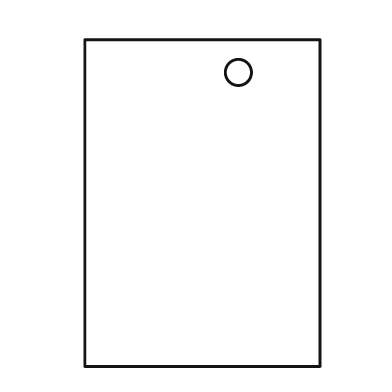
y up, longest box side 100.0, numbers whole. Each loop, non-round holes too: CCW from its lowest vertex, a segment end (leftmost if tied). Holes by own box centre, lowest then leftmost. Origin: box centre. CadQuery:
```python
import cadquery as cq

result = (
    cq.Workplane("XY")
    .moveTo(-36.0, -50.0)
    .lineTo(36.0, -50.0)
    .lineTo(36.0, 50.0)
    .lineTo(-36.0, 50.0)
    .close()
    .moveTo(11.0, 40.0)
    .circle(4.0)
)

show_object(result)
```